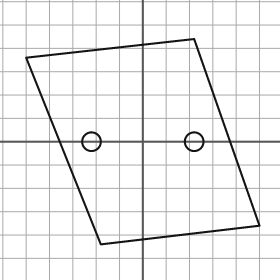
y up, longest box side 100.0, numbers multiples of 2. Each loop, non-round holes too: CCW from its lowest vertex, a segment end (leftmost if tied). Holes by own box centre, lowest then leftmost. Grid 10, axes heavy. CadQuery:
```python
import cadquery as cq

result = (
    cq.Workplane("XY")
    .moveTo(-18.0, -44.0)
    .lineTo(50.0, -36.0)
    .lineTo(22.0, 44.0)
    .lineTo(-50.0, 36.0)
    .close()
    .moveTo(-22.0, 0.0)
    .circle(4.0)
    .moveTo(22.0, 0.0)
    .circle(4.0)
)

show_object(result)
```